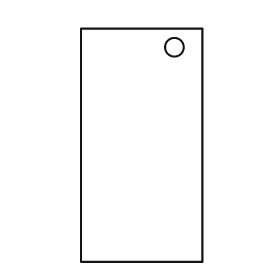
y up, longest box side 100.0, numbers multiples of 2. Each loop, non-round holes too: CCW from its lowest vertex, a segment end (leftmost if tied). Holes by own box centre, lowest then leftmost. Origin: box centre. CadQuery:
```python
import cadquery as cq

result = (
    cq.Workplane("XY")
    .moveTo(-26.0, -50.0)
    .lineTo(26.0, -50.0)
    .lineTo(26.0, 50.0)
    .lineTo(-26.0, 50.0)
    .close()
    .moveTo(14.0, 42.0)
    .circle(4.0)
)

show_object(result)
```